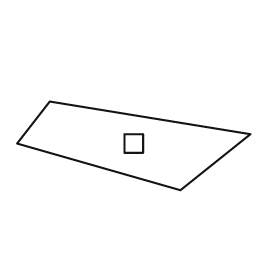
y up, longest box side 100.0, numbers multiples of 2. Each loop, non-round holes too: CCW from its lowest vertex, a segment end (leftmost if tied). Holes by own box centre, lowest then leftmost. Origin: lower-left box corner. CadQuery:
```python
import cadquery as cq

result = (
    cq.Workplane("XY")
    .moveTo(70.0, 0.0)
    .lineTo(100.0, 24.0)
    .lineTo(14.0, 38.0)
    .lineTo(0.0, 20.0)
    .close()
    .moveTo(46.0, 16.0)
    .lineTo(54.0, 16.0)
    .lineTo(54.0, 24.0)
    .lineTo(46.0, 24.0)
    .close()
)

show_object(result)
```